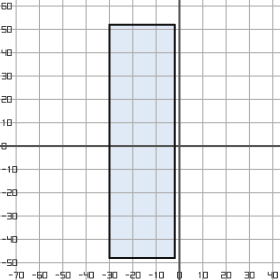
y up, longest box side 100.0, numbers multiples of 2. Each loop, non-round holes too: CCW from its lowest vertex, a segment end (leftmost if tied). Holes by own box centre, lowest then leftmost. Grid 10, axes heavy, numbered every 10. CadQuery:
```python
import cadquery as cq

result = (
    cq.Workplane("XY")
    .moveTo(-30.0, -48.0)
    .lineTo(-2.0, -48.0)
    .lineTo(-2.0, 52.0)
    .lineTo(-30.0, 52.0)
    .close()
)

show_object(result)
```